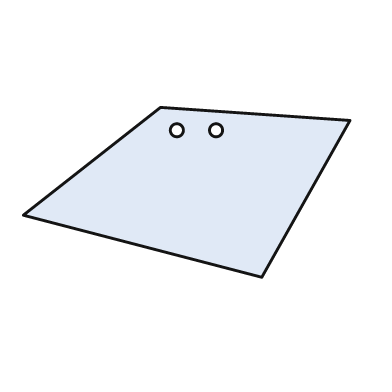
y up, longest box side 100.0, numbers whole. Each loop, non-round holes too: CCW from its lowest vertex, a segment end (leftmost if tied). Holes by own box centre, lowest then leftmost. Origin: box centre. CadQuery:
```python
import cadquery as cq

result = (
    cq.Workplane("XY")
    .moveTo(23.0, -26.0)
    .lineTo(50.0, 22.0)
    .lineTo(-8.0, 26.0)
    .lineTo(-50.0, -7.0)
    .close()
    .moveTo(-3.0, 19.0)
    .circle(2.0)
    .moveTo(9.0, 19.0)
    .circle(2.0)
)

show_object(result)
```